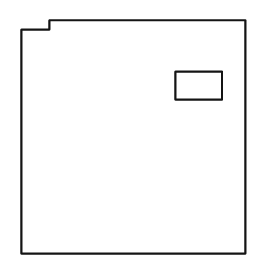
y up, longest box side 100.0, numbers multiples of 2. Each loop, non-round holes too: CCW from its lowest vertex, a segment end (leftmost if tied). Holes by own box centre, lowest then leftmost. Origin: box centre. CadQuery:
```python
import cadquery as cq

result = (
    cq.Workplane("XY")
    .moveTo(-48.0, -50.0)
    .lineTo(48.0, -50.0)
    .lineTo(48.0, 50.0)
    .lineTo(-36.0, 50.0)
    .lineTo(-36.0, 46.0)
    .lineTo(-48.0, 46.0)
    .close()
    .moveTo(18.0, 16.0)
    .lineTo(38.0, 16.0)
    .lineTo(38.0, 28.0)
    .lineTo(18.0, 28.0)
    .close()
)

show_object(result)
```